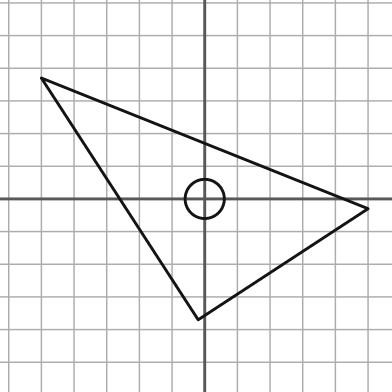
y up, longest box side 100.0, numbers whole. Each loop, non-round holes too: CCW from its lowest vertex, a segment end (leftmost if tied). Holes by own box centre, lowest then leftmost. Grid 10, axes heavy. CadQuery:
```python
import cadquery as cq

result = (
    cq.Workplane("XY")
    .moveTo(-2.0, -37.0)
    .lineTo(50.0, -3.0)
    .lineTo(-50.0, 37.0)
    .close()
    .moveTo(0.0, 0.0)
    .circle(6.0)
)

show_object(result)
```